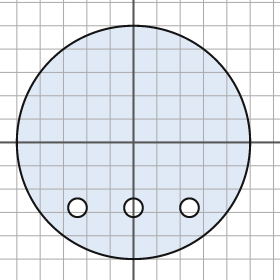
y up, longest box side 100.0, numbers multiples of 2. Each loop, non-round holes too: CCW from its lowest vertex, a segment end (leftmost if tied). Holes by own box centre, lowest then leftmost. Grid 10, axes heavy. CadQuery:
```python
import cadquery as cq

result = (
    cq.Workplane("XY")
    .moveTo(0.0, 0.0)
    .circle(50.0)
    .moveTo(-24.0, -28.0)
    .circle(4.0)
    .moveTo(0.0, -28.0)
    .circle(4.0)
    .moveTo(24.0, -28.0)
    .circle(4.0)
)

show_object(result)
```